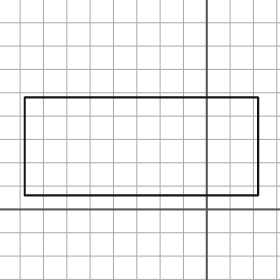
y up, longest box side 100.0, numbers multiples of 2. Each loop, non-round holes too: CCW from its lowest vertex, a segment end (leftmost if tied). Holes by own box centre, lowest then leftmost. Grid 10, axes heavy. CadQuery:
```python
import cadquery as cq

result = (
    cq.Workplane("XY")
    .moveTo(-78.0, 6.0)
    .lineTo(22.0, 6.0)
    .lineTo(22.0, 48.0)
    .lineTo(-78.0, 48.0)
    .close()
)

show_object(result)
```